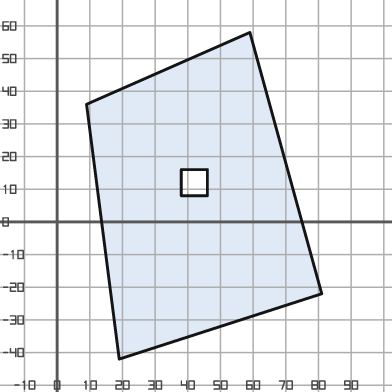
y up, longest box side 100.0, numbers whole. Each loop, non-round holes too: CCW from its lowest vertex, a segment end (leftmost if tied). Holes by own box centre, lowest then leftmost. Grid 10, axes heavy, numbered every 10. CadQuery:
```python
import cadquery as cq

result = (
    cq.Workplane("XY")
    .moveTo(19.0, -42.0)
    .lineTo(81.0, -22.0)
    .lineTo(59.0, 58.0)
    .lineTo(9.0, 36.0)
    .close()
    .moveTo(38.0, 8.0)
    .lineTo(46.0, 8.0)
    .lineTo(46.0, 16.0)
    .lineTo(38.0, 16.0)
    .close()
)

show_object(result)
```